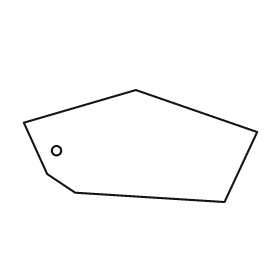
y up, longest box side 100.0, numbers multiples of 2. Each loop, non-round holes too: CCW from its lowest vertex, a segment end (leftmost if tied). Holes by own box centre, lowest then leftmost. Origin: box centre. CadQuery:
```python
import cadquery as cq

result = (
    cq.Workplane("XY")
    .moveTo(36.0, -24.0)
    .lineTo(50.0, 6.0)
    .lineTo(-2.0, 24.0)
    .lineTo(-50.0, 10.0)
    .lineTo(-40.0, -12.0)
    .lineTo(-28.0, -20.0)
    .close()
    .moveTo(-36.0, -2.0)
    .circle(2.0)
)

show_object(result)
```